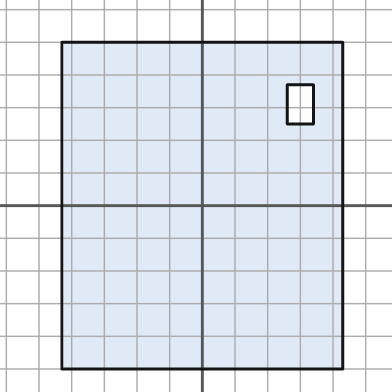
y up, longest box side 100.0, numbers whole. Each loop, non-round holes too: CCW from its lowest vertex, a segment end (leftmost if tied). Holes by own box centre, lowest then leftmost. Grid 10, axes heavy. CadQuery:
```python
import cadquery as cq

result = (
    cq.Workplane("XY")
    .moveTo(-43.0, -50.0)
    .lineTo(43.0, -50.0)
    .lineTo(43.0, 50.0)
    .lineTo(-43.0, 50.0)
    .close()
    .moveTo(26.0, 25.0)
    .lineTo(34.0, 25.0)
    .lineTo(34.0, 37.0)
    .lineTo(26.0, 37.0)
    .close()
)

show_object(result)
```